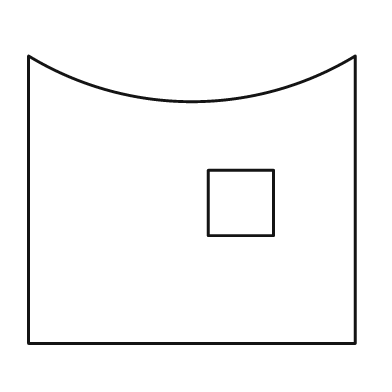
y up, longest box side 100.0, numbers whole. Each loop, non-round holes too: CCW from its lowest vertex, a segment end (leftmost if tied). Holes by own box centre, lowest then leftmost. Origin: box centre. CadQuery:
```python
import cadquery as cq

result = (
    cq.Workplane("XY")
    .moveTo(-50.0, -44.0)
    .lineTo(50.0, -44.0)
    .lineTo(50.0, 44.0)
    .threePointArc((0.0, 30.0), (-50.0, 44.0))
    .close()
    .moveTo(5.0, -11.0)
    .lineTo(25.0, -11.0)
    .lineTo(25.0, 9.0)
    .lineTo(5.0, 9.0)
    .close()
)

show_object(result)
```